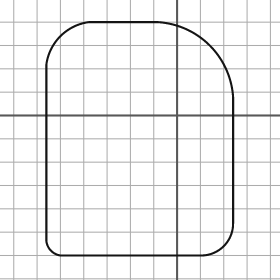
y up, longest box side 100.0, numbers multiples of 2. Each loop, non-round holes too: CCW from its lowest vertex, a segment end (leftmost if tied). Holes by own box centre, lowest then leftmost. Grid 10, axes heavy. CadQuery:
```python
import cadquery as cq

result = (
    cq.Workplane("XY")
    .moveTo(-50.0, -60.0)
    .lineTo(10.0, -60.0)
    .threePointArc((20.0, -56.0), (24.0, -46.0))
    .lineTo(24.0, 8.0)
    .threePointArc((14.0, 30.0), (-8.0, 40.0))
    .lineTo(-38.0, 40.0)
    .threePointArc((-50.0, 34.0), (-56.0, 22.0))
    .lineTo(-56.0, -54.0)
    .threePointArc((-54.0, -58.0), (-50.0, -60.0))
    .close()
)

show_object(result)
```